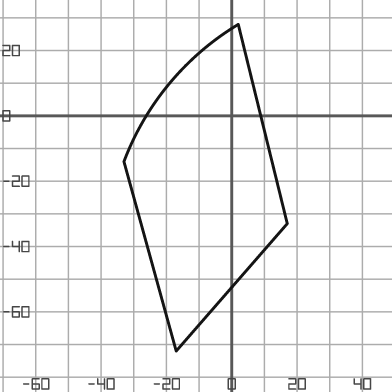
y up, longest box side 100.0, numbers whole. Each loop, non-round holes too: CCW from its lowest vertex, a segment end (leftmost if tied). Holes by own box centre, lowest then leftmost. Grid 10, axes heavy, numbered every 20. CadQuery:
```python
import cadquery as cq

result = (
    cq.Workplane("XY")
    .moveTo(-17.0, -72.0)
    .lineTo(17.0, -33.0)
    .lineTo(2.0, 28.0)
    .threePointArc((-19.0, 10.0), (-33.0, -14.0))
    .close()
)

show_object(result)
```